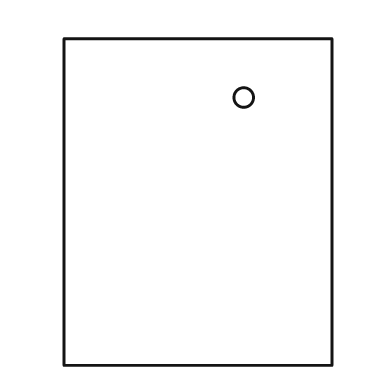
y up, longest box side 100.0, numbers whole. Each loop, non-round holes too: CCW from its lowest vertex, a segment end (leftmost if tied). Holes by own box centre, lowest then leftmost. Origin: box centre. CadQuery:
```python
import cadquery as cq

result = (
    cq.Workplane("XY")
    .moveTo(-41.0, -50.0)
    .lineTo(41.0, -50.0)
    .lineTo(41.0, 50.0)
    .lineTo(-41.0, 50.0)
    .close()
    .moveTo(14.0, 32.0)
    .circle(3.0)
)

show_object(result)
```